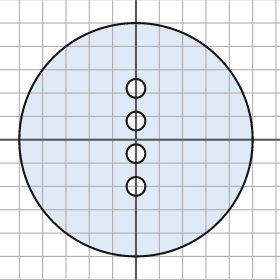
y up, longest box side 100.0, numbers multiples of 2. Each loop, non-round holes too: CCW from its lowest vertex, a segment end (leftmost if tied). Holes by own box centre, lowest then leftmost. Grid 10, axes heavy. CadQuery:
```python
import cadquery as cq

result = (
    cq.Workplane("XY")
    .moveTo(0.0, 0.0)
    .circle(50.0)
    .moveTo(0.0, -20.0)
    .circle(4.0)
    .moveTo(0.0, -6.0)
    .circle(4.0)
    .moveTo(0.0, 8.0)
    .circle(4.0)
    .moveTo(0.0, 22.0)
    .circle(4.0)
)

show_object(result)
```